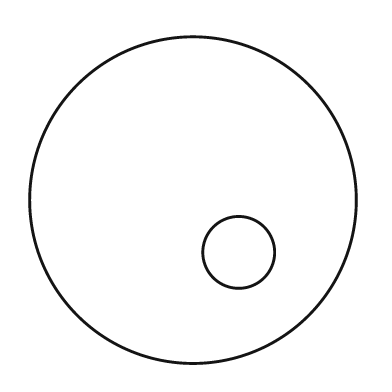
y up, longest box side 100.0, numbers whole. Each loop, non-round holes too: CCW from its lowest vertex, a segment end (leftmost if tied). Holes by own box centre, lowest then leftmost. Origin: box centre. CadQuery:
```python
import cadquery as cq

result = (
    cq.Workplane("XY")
    .moveTo(0.0, 0.0)
    .circle(50.0)
    .moveTo(14.0, -16.0)
    .circle(11.0)
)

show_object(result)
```